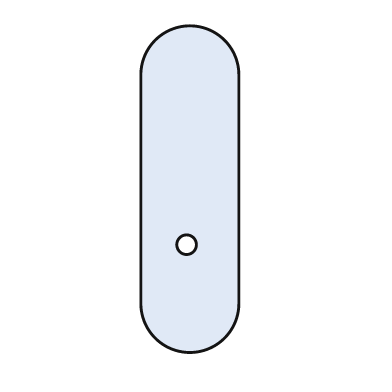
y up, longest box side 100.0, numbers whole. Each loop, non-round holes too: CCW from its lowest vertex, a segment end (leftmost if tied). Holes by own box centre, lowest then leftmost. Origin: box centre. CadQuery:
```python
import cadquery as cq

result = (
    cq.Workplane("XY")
    .moveTo(-15.0, -35.0)
    .threePointArc((0.0, -50.0), (15.0, -35.0))
    .lineTo(15.0, 35.0)
    .threePointArc((0.0, 50.0), (-15.0, 35.0))
    .close()
    .moveTo(-1.0, -17.0)
    .circle(3.0)
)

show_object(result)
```